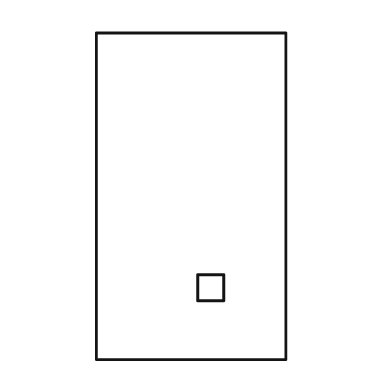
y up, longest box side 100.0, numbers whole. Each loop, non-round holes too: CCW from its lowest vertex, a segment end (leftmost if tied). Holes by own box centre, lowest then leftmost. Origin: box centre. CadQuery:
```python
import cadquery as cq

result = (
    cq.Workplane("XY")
    .moveTo(-29.0, -50.0)
    .lineTo(29.0, -50.0)
    .lineTo(29.0, 50.0)
    .lineTo(-29.0, 50.0)
    .close()
    .moveTo(2.0, -32.0)
    .lineTo(10.0, -32.0)
    .lineTo(10.0, -24.0)
    .lineTo(2.0, -24.0)
    .close()
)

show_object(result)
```